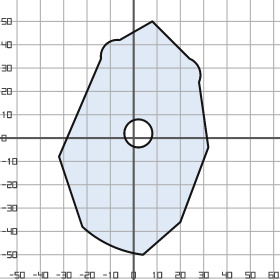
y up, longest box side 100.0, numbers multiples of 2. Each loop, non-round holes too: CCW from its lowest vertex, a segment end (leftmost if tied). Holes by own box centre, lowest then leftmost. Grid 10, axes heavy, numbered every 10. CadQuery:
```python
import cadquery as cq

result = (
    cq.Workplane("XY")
    .moveTo(4.0, -50.0)
    .lineTo(20.0, -36.0)
    .lineTo(32.0, -4.0)
    .lineTo(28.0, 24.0)
    .threePointArc((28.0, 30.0), (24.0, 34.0))
    .lineTo(8.0, 50.0)
    .lineTo(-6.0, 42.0)
    .threePointArc((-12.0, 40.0), (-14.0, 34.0))
    .lineTo(-32.0, -8.0)
    .lineTo(-22.0, -38.0)
    .threePointArc((-10.0, -46.0), (4.0, -50.0))
    .close()
    .moveTo(2.0, 2.0)
    .circle(6.0)
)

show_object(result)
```